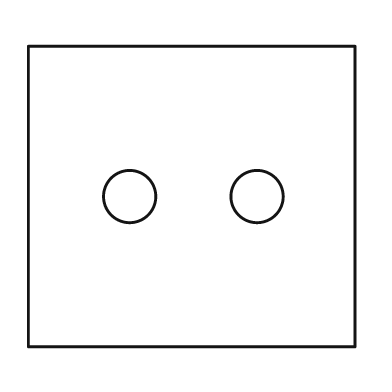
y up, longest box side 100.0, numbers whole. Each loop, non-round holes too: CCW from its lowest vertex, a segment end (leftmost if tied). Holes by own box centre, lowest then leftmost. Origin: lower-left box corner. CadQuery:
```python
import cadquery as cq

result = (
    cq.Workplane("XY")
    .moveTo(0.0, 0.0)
    .lineTo(100.0, 0.0)
    .lineTo(100.0, 92.0)
    .lineTo(0.0, 92.0)
    .close()
    .moveTo(31.0, 46.0)
    .circle(8.0)
    .moveTo(70.0, 46.0)
    .circle(8.0)
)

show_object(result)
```